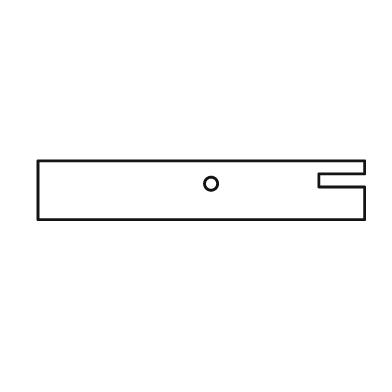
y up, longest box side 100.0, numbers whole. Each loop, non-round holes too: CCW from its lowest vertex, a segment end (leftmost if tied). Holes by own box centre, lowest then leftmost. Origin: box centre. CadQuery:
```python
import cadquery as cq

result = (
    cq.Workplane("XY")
    .moveTo(-50.0, -9.0)
    .lineTo(50.0, -9.0)
    .lineTo(50.0, 1.0)
    .lineTo(36.0, 1.0)
    .lineTo(36.0, 5.0)
    .lineTo(50.0, 5.0)
    .lineTo(50.0, 9.0)
    .lineTo(-50.0, 9.0)
    .close()
    .moveTo(3.0, 2.0)
    .circle(2.0)
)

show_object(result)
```